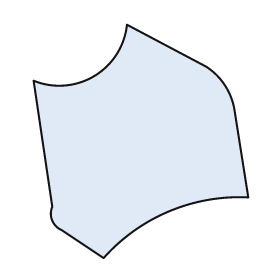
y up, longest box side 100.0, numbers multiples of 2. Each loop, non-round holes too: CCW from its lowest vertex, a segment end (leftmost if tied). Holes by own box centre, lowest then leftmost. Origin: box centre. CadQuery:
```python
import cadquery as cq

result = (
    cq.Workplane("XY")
    .moveTo(-16.0, -50.0)
    .threePointArc((12.0, -30.0), (46.0, -24.0))
    .lineTo(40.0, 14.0)
    .threePointArc((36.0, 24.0), (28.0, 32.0))
    .lineTo(-6.0, 50.0)
    .threePointArc((-20.0, 28.0), (-46.0, 26.0))
    .lineTo(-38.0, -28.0)
    .threePointArc((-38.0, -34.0), (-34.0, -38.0))
    .close()
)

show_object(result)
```